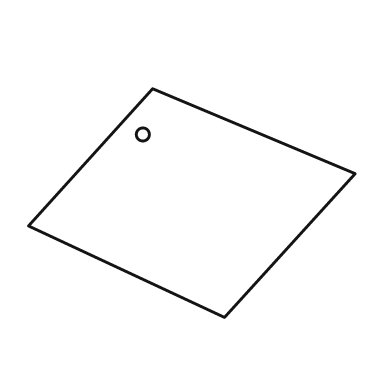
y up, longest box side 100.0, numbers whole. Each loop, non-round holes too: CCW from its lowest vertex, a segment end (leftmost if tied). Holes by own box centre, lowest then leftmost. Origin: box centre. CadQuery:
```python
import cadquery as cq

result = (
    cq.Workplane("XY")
    .moveTo(10.0, -35.0)
    .lineTo(50.0, 9.0)
    .lineTo(-12.0, 35.0)
    .lineTo(-50.0, -7.0)
    .close()
    .moveTo(-15.0, 21.0)
    .circle(2.0)
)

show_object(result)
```